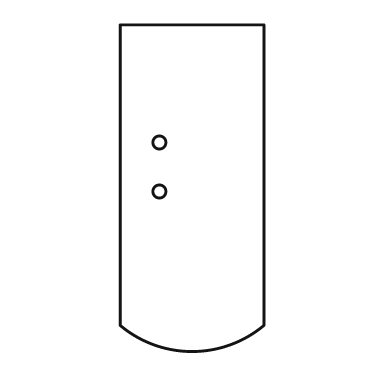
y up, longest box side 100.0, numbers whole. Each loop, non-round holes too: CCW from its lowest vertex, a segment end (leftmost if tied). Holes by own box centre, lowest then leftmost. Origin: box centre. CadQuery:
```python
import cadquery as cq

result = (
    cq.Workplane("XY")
    .moveTo(-22.0, -42.0)
    .threePointArc((0.0, -50.0), (22.0, -42.0))
    .lineTo(22.0, 50.0)
    .lineTo(-22.0, 50.0)
    .close()
    .moveTo(-10.0, -1.0)
    .circle(2.0)
    .moveTo(-10.0, 14.0)
    .circle(2.0)
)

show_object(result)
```